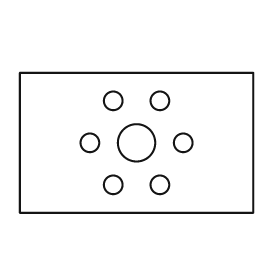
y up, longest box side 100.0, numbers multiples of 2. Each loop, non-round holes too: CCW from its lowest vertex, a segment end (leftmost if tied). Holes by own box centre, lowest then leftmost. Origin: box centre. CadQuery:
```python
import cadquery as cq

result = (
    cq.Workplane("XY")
    .moveTo(-50.0, -30.0)
    .lineTo(50.0, -30.0)
    .lineTo(50.0, 30.0)
    .lineTo(-50.0, 30.0)
    .close()
    .moveTo(-10.0, -18.0)
    .circle(4.0)
    .moveTo(10.0, -18.0)
    .circle(4.0)
    .moveTo(-20.0, 0.0)
    .circle(4.0)
    .moveTo(0.0, 0.0)
    .circle(8.0)
    .moveTo(20.0, 0.0)
    .circle(4.0)
    .moveTo(-10.0, 18.0)
    .circle(4.0)
    .moveTo(10.0, 18.0)
    .circle(4.0)
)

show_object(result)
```